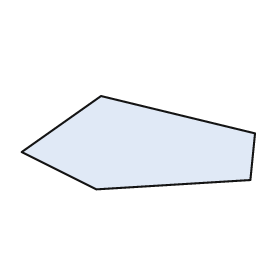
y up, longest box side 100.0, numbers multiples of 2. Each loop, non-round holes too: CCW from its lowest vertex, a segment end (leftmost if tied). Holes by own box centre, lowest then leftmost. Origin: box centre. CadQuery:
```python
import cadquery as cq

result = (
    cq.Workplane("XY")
    .moveTo(-18.0, -20.0)
    .lineTo(48.0, -16.0)
    .lineTo(50.0, 4.0)
    .lineTo(-16.0, 20.0)
    .lineTo(-50.0, -4.0)
    .close()
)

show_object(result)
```